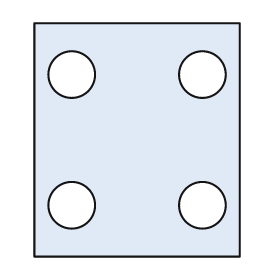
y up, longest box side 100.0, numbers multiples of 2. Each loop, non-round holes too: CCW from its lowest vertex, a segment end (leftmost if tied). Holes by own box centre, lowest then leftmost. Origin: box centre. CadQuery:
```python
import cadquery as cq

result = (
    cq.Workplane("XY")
    .moveTo(-44.0, -50.0)
    .lineTo(44.0, -50.0)
    .lineTo(44.0, 50.0)
    .lineTo(-44.0, 50.0)
    .close()
    .moveTo(-28.0, -28.0)
    .circle(10.0)
    .moveTo(28.0, -28.0)
    .circle(10.0)
    .moveTo(-28.0, 28.0)
    .circle(10.0)
    .moveTo(28.0, 28.0)
    .circle(10.0)
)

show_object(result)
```